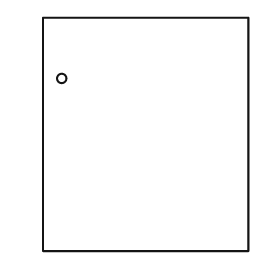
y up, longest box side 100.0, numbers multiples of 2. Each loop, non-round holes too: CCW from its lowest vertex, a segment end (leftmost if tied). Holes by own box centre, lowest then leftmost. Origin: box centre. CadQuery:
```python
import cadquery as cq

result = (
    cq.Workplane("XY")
    .moveTo(-44.0, -50.0)
    .lineTo(44.0, -50.0)
    .lineTo(44.0, 50.0)
    .lineTo(-44.0, 50.0)
    .close()
    .moveTo(-36.0, 24.0)
    .circle(2.0)
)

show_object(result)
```